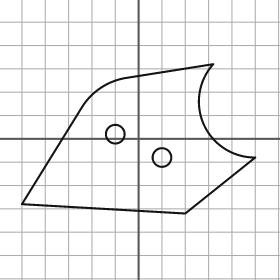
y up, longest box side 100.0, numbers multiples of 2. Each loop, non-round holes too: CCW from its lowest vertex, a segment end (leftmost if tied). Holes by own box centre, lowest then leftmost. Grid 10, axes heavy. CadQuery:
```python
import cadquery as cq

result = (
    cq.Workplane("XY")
    .moveTo(20.0, -32.0)
    .lineTo(50.0, -8.0)
    .threePointArc((28.0, 6.0), (32.0, 32.0))
    .lineTo(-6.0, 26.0)
    .threePointArc((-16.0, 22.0), (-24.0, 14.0))
    .lineTo(-50.0, -28.0)
    .close()
    .moveTo(10.0, -8.0)
    .circle(4.0)
    .moveTo(-10.0, 2.0)
    .circle(4.0)
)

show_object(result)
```